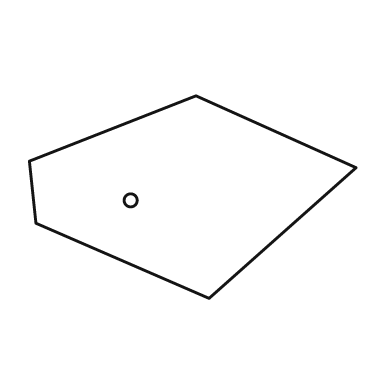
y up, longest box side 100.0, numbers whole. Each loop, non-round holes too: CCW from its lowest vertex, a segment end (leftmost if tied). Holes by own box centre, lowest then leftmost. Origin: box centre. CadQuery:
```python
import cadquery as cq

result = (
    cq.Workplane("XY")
    .moveTo(5.0, -31.0)
    .lineTo(50.0, 9.0)
    .lineTo(1.0, 31.0)
    .lineTo(-50.0, 11.0)
    .lineTo(-48.0, -8.0)
    .close()
    .moveTo(-19.0, -1.0)
    .circle(2.0)
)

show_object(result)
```